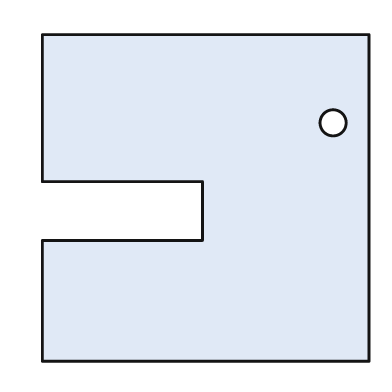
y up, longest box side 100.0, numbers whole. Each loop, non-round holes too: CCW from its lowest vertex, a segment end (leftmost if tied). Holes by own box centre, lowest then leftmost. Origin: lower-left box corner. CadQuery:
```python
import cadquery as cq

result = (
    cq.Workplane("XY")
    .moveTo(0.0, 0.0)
    .lineTo(100.0, 0.0)
    .lineTo(100.0, 100.0)
    .lineTo(0.0, 100.0)
    .lineTo(0.0, 55.0)
    .lineTo(49.0, 55.0)
    .lineTo(49.0, 37.0)
    .lineTo(0.0, 37.0)
    .close()
    .moveTo(89.0, 73.0)
    .circle(4.0)
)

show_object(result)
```